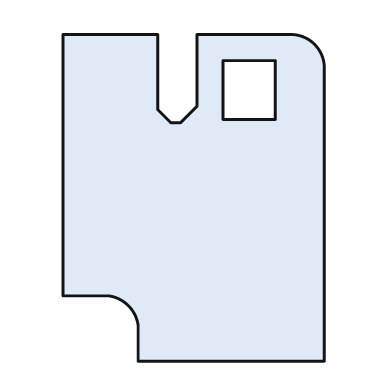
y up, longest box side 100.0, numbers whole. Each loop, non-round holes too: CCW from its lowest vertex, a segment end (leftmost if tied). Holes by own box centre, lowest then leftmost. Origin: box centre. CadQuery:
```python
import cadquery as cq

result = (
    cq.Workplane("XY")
    .moveTo(-17.0, -50.0)
    .lineTo(40.0, -50.0)
    .lineTo(40.0, 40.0)
    .threePointArc((37.0, 47.0), (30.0, 50.0))
    .lineTo(1.0, 50.0)
    .lineTo(1.0, 28.0)
    .lineTo(-4.0, 23.0)
    .lineTo(-7.0, 23.0)
    .lineTo(-11.0, 27.0)
    .lineTo(-11.0, 50.0)
    .lineTo(-40.0, 50.0)
    .lineTo(-40.0, -30.0)
    .lineTo(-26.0, -30.0)
    .threePointArc((-20.0, -33.0), (-17.0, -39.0))
    .close()
    .moveTo(9.0, 24.0)
    .lineTo(25.0, 24.0)
    .lineTo(25.0, 42.0)
    .lineTo(9.0, 42.0)
    .close()
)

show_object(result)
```